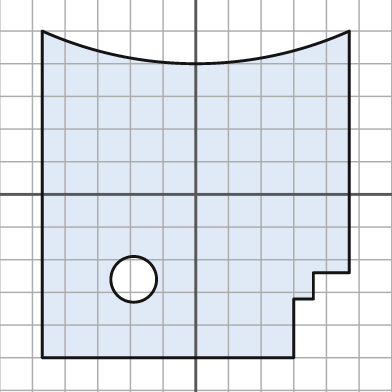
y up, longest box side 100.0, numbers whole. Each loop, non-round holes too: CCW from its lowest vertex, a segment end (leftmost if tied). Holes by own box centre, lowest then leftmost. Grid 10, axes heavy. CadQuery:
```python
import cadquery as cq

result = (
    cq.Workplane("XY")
    .moveTo(-47.0, -50.0)
    .lineTo(30.0, -50.0)
    .lineTo(30.0, -32.0)
    .lineTo(36.0, -32.0)
    .lineTo(36.0, -24.0)
    .lineTo(47.0, -24.0)
    .lineTo(47.0, 50.0)
    .threePointArc((0.0, 40.0), (-47.0, 50.0))
    .close()
    .moveTo(-19.0, -26.0)
    .circle(7.0)
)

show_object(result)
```